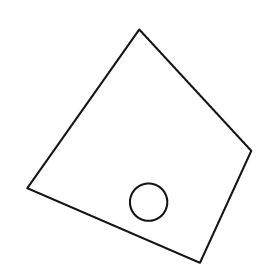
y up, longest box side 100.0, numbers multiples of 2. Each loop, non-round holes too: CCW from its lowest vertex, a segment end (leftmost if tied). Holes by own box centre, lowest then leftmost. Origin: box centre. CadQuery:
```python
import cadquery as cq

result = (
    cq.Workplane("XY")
    .moveTo(26.0, -50.0)
    .lineTo(48.0, -2.0)
    .lineTo(0.0, 50.0)
    .lineTo(-48.0, -18.0)
    .close()
    .moveTo(4.0, -24.0)
    .circle(8.0)
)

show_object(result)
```